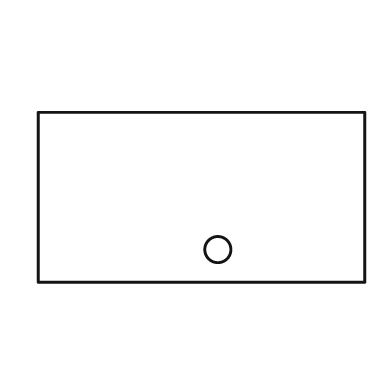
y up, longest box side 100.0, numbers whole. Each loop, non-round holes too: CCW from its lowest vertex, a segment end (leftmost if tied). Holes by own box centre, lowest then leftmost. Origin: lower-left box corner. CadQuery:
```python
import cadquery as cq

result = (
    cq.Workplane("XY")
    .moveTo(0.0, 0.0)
    .lineTo(100.0, 0.0)
    .lineTo(100.0, 52.0)
    .lineTo(0.0, 52.0)
    .close()
    .moveTo(55.0, 10.0)
    .circle(4.0)
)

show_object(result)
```